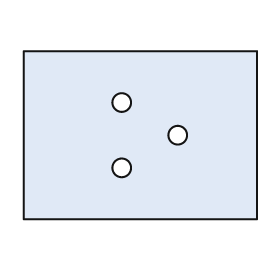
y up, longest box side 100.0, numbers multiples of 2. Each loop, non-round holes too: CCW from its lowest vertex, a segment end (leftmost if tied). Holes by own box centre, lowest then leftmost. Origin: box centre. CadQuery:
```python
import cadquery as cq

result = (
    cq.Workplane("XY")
    .moveTo(-50.0, -36.0)
    .lineTo(50.0, -36.0)
    .lineTo(50.0, 36.0)
    .lineTo(-50.0, 36.0)
    .close()
    .moveTo(-8.0, -14.0)
    .circle(4.0)
    .moveTo(16.0, 0.0)
    .circle(4.0)
    .moveTo(-8.0, 14.0)
    .circle(4.0)
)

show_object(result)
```